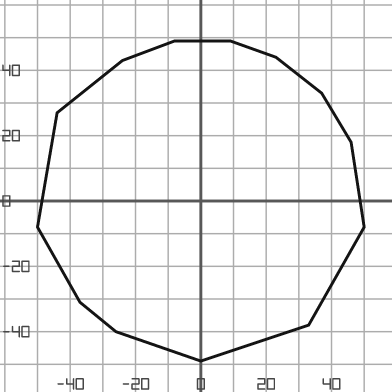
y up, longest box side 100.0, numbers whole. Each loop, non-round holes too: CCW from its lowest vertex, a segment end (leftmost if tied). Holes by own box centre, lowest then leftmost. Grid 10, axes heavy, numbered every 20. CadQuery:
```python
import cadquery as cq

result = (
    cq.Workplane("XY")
    .moveTo(0.0, -49.0)
    .lineTo(33.0, -38.0)
    .lineTo(50.0, -8.0)
    .lineTo(46.0, 18.0)
    .lineTo(37.0, 33.0)
    .lineTo(23.0, 44.0)
    .lineTo(9.0, 49.0)
    .lineTo(-8.0, 49.0)
    .lineTo(-24.0, 43.0)
    .lineTo(-44.0, 27.0)
    .lineTo(-50.0, -8.0)
    .lineTo(-37.0, -31.0)
    .lineTo(-26.0, -40.0)
    .close()
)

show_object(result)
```